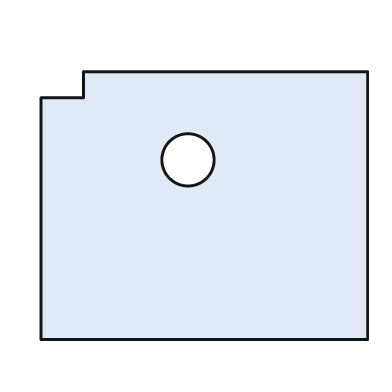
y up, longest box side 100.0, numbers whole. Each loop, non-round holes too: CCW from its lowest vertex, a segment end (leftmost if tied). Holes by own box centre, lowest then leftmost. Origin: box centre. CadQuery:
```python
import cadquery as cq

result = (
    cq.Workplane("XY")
    .moveTo(-50.0, -41.0)
    .lineTo(50.0, -41.0)
    .lineTo(50.0, 41.0)
    .lineTo(-37.0, 41.0)
    .lineTo(-37.0, 33.0)
    .lineTo(-50.0, 33.0)
    .close()
    .moveTo(-5.0, 14.0)
    .circle(8.0)
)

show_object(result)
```